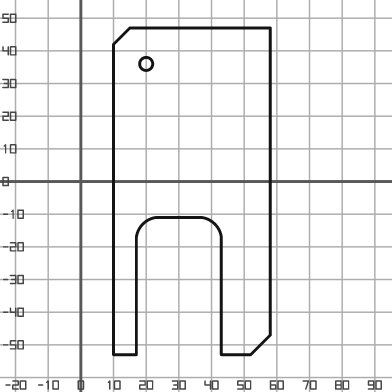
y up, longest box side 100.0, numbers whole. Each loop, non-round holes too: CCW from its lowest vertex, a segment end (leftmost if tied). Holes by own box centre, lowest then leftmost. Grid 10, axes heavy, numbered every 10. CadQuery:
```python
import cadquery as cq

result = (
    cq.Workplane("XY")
    .moveTo(10.0, -53.0)
    .lineTo(17.0, -53.0)
    .lineTo(17.0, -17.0)
    .threePointArc((19.0, -13.0), (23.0, -11.0))
    .lineTo(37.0, -11.0)
    .threePointArc((41.0, -13.0), (43.0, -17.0))
    .lineTo(43.0, -53.0)
    .lineTo(52.0, -53.0)
    .lineTo(58.0, -47.0)
    .lineTo(58.0, 47.0)
    .lineTo(15.0, 47.0)
    .lineTo(10.0, 42.0)
    .close()
    .moveTo(20.0, 36.0)
    .circle(2.0)
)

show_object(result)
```